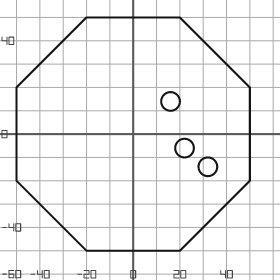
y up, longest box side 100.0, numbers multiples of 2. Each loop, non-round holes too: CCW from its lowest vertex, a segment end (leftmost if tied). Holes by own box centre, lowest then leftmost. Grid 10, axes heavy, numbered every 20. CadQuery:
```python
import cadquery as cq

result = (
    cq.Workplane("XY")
    .moveTo(-20.0, -50.0)
    .lineTo(20.0, -50.0)
    .lineTo(50.0, -20.0)
    .lineTo(50.0, 20.0)
    .lineTo(20.0, 50.0)
    .lineTo(-20.0, 50.0)
    .lineTo(-50.0, 20.0)
    .lineTo(-50.0, -20.0)
    .close()
    .moveTo(32.0, -14.0)
    .circle(4.0)
    .moveTo(22.0, -6.0)
    .circle(4.0)
    .moveTo(16.0, 14.0)
    .circle(4.0)
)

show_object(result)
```